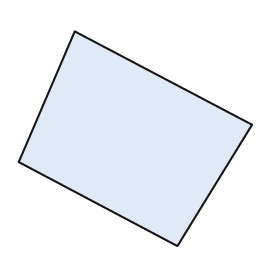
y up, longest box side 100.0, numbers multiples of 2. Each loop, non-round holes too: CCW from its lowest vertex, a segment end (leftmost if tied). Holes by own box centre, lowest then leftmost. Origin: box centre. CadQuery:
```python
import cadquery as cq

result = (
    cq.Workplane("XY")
    .moveTo(18.0, -46.0)
    .lineTo(50.0, 6.0)
    .lineTo(-26.0, 46.0)
    .lineTo(-50.0, -10.0)
    .close()
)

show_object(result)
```